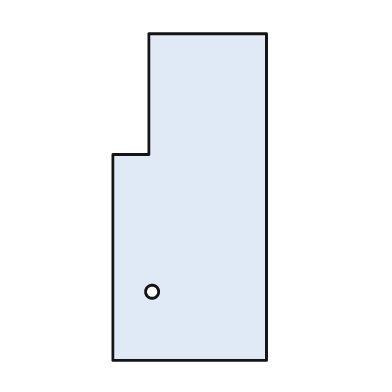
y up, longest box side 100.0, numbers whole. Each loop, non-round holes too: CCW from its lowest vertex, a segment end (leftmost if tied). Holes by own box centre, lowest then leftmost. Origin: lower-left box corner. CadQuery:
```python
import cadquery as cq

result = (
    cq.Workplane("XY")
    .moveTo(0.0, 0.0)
    .lineTo(47.0, 0.0)
    .lineTo(47.0, 100.0)
    .lineTo(11.0, 100.0)
    .lineTo(11.0, 63.0)
    .lineTo(0.0, 63.0)
    .close()
    .moveTo(12.0, 21.0)
    .circle(2.0)
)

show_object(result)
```